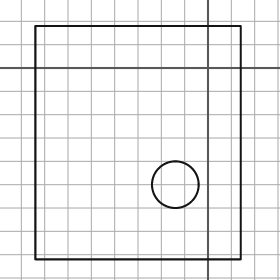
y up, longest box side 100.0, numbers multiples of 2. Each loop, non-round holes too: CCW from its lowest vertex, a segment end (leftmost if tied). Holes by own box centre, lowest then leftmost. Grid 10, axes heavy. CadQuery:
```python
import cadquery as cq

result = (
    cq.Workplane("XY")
    .moveTo(-74.0, -82.0)
    .lineTo(14.0, -82.0)
    .lineTo(14.0, 18.0)
    .lineTo(-74.0, 18.0)
    .close()
    .moveTo(-14.0, -50.0)
    .circle(10.0)
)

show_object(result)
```